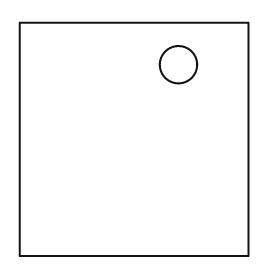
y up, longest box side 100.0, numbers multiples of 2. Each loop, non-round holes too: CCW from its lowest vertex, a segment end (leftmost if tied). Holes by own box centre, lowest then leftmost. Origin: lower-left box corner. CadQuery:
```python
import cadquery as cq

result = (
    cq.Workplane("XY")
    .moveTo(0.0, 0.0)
    .lineTo(98.0, 0.0)
    .lineTo(98.0, 100.0)
    .lineTo(0.0, 100.0)
    .close()
    .moveTo(68.0, 82.0)
    .circle(8.0)
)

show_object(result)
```